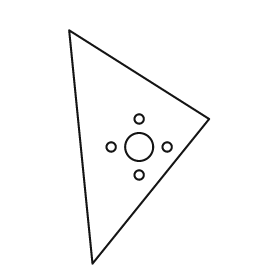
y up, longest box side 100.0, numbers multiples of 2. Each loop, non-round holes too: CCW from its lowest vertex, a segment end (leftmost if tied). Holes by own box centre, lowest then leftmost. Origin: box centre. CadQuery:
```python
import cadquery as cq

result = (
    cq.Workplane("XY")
    .moveTo(-20.0, -50.0)
    .lineTo(30.0, 12.0)
    .lineTo(-30.0, 50.0)
    .close()
    .moveTo(0.0, -12.0)
    .circle(2.0)
    .moveTo(-12.0, 0.0)
    .circle(2.0)
    .moveTo(0.0, 0.0)
    .circle(6.0)
    .moveTo(12.0, 0.0)
    .circle(2.0)
    .moveTo(0.0, 12.0)
    .circle(2.0)
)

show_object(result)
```